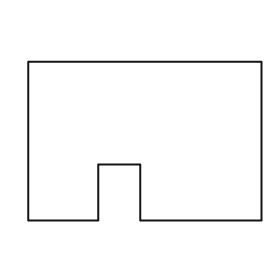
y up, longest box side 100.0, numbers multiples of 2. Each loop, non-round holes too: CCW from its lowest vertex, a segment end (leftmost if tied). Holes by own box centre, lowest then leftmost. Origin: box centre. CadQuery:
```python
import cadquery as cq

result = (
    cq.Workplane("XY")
    .moveTo(-50.0, -34.0)
    .lineTo(-20.0, -34.0)
    .lineTo(-20.0, -10.0)
    .lineTo(-2.0, -10.0)
    .lineTo(-2.0, -34.0)
    .lineTo(50.0, -34.0)
    .lineTo(50.0, 34.0)
    .lineTo(-50.0, 34.0)
    .close()
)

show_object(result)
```